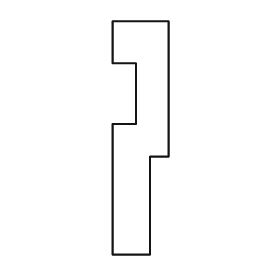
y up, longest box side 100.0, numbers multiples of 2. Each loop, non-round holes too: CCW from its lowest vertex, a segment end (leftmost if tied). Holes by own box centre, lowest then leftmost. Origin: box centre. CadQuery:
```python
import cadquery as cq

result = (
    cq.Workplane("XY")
    .moveTo(-12.0, -50.0)
    .lineTo(4.0, -50.0)
    .lineTo(4.0, -8.0)
    .lineTo(12.0, -8.0)
    .lineTo(12.0, 50.0)
    .lineTo(-12.0, 50.0)
    .lineTo(-12.0, 32.0)
    .lineTo(-2.0, 32.0)
    .lineTo(-2.0, 6.0)
    .lineTo(-12.0, 6.0)
    .close()
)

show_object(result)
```